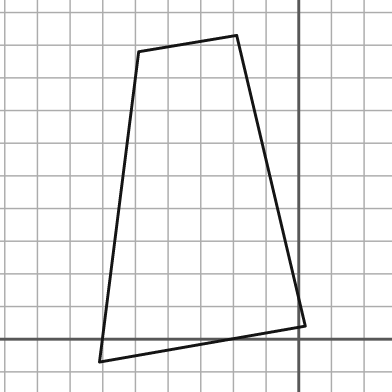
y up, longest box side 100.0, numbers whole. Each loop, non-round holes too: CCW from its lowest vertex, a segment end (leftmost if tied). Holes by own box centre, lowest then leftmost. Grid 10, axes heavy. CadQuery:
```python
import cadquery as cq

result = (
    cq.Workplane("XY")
    .moveTo(-61.0, -7.0)
    .lineTo(2.0, 4.0)
    .lineTo(-19.0, 93.0)
    .lineTo(-49.0, 88.0)
    .close()
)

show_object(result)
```